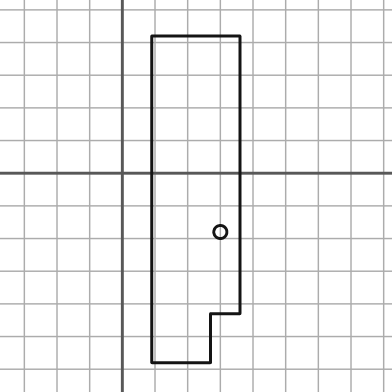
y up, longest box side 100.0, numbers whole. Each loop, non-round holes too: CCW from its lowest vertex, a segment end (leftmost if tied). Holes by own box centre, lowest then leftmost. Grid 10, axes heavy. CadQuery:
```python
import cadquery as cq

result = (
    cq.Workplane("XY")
    .moveTo(9.0, -58.0)
    .lineTo(27.0, -58.0)
    .lineTo(27.0, -43.0)
    .lineTo(36.0, -43.0)
    .lineTo(36.0, 42.0)
    .lineTo(9.0, 42.0)
    .close()
    .moveTo(30.0, -18.0)
    .circle(2.0)
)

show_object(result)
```